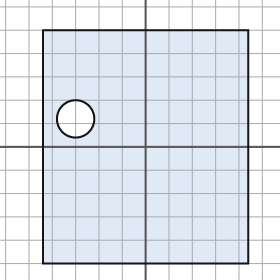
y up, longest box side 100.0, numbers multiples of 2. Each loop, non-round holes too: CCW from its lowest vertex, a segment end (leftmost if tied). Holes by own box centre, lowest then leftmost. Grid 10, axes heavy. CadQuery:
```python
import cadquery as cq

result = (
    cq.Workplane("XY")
    .moveTo(-44.0, -50.0)
    .lineTo(44.0, -50.0)
    .lineTo(44.0, 50.0)
    .lineTo(-44.0, 50.0)
    .close()
    .moveTo(-30.0, 12.0)
    .circle(8.0)
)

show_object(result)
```